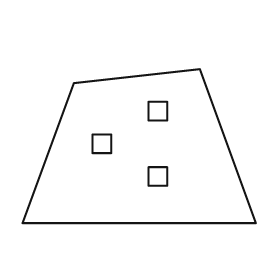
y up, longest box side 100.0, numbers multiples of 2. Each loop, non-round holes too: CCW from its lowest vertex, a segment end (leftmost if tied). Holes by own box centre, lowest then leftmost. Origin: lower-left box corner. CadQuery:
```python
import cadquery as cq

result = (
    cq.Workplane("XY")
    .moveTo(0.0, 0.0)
    .lineTo(100.0, 0.0)
    .lineTo(76.0, 66.0)
    .lineTo(22.0, 60.0)
    .close()
    .moveTo(54.0, 16.0)
    .lineTo(62.0, 16.0)
    .lineTo(62.0, 24.0)
    .lineTo(54.0, 24.0)
    .close()
    .moveTo(30.0, 30.0)
    .lineTo(38.0, 30.0)
    .lineTo(38.0, 38.0)
    .lineTo(30.0, 38.0)
    .close()
    .moveTo(54.0, 44.0)
    .lineTo(62.0, 44.0)
    .lineTo(62.0, 52.0)
    .lineTo(54.0, 52.0)
    .close()
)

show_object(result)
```